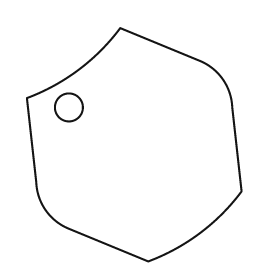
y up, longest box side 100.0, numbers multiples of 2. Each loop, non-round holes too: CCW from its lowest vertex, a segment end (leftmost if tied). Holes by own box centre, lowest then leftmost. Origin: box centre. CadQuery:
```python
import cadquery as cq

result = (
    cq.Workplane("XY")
    .moveTo(6.0, -50.0)
    .threePointArc((28.0, -38.0), (46.0, -20.0))
    .lineTo(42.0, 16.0)
    .threePointArc((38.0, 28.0), (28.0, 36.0))
    .lineTo(-6.0, 50.0)
    .threePointArc((-24.0, 32.0), (-46.0, 20.0))
    .lineTo(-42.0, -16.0)
    .threePointArc((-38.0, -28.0), (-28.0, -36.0))
    .close()
    .moveTo(-28.0, 16.0)
    .circle(6.0)
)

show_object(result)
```